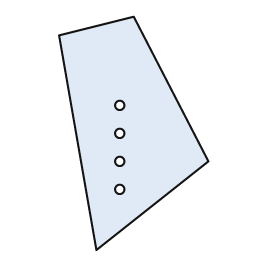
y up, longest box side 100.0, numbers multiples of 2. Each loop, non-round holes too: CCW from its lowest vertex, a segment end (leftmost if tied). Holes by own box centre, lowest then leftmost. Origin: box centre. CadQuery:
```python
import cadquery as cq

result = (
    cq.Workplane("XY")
    .moveTo(-16.0, -50.0)
    .lineTo(32.0, -12.0)
    .lineTo(0.0, 50.0)
    .lineTo(-32.0, 42.0)
    .close()
    .moveTo(-6.0, -24.0)
    .circle(2.0)
    .moveTo(-6.0, -12.0)
    .circle(2.0)
    .moveTo(-6.0, 0.0)
    .circle(2.0)
    .moveTo(-6.0, 12.0)
    .circle(2.0)
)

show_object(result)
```